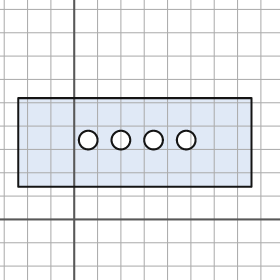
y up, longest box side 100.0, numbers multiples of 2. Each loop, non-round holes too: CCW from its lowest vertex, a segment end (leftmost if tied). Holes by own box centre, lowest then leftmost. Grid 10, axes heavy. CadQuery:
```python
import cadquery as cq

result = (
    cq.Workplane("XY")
    .moveTo(-24.0, 14.0)
    .lineTo(76.0, 14.0)
    .lineTo(76.0, 52.0)
    .lineTo(-24.0, 52.0)
    .close()
    .moveTo(6.0, 34.0)
    .circle(4.0)
    .moveTo(20.0, 34.0)
    .circle(4.0)
    .moveTo(34.0, 34.0)
    .circle(4.0)
    .moveTo(48.0, 34.0)
    .circle(4.0)
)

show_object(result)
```